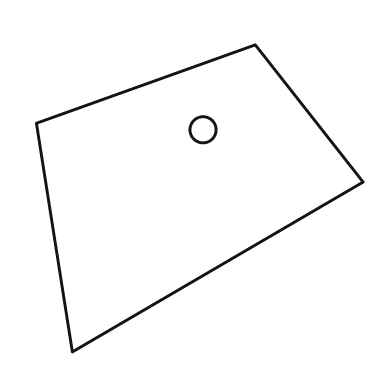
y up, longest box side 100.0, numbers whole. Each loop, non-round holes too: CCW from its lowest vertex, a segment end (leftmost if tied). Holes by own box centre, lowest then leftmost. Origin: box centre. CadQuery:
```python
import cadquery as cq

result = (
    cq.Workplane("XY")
    .moveTo(-39.0, -47.0)
    .lineTo(50.0, 5.0)
    .lineTo(17.0, 47.0)
    .lineTo(-50.0, 23.0)
    .close()
    .moveTo(1.0, 21.0)
    .circle(4.0)
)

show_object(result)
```